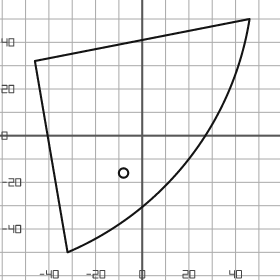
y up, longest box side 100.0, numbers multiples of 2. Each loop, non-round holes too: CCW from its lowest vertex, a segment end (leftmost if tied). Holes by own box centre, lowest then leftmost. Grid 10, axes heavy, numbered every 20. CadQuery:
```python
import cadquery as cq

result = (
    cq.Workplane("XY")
    .moveTo(-32.0, -50.0)
    .threePointArc((20.0, -10.0), (46.0, 50.0))
    .lineTo(-46.0, 32.0)
    .close()
    .moveTo(-8.0, -16.0)
    .circle(2.0)
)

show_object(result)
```